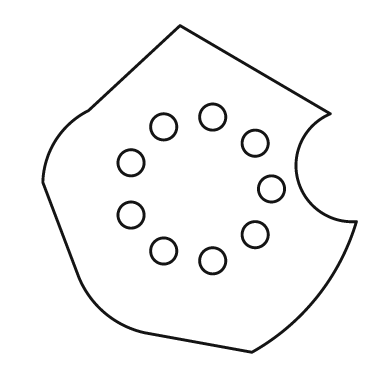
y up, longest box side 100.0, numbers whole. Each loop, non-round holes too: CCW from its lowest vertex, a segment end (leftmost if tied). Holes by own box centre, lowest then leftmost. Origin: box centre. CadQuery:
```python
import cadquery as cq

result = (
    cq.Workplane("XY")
    .moveTo(16.0, -50.0)
    .threePointArc((36.0, -33.0), (48.0, -10.0))
    .threePointArc((30.0, 3.0), (40.0, 23.0))
    .lineTo(-6.0, 50.0)
    .lineTo(-34.0, 24.0)
    .threePointArc((-44.0, 15.0), (-48.0, 2.0))
    .lineTo(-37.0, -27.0)
    .threePointArc((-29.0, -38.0), (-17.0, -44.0))
    .close()
    .moveTo(4.0, -22.0)
    .circle(4.0)
    .moveTo(-11.0, -19.0)
    .circle(4.0)
    .moveTo(17.0, -14.0)
    .circle(4.0)
    .moveTo(-21.0, -8.0)
    .circle(4.0)
    .moveTo(22.0, 0.0)
    .circle(4.0)
    .moveTo(-21.0, 8.0)
    .circle(4.0)
    .moveTo(17.0, 14.0)
    .circle(4.0)
    .moveTo(-11.0, 19.0)
    .circle(4.0)
    .moveTo(4.0, 22.0)
    .circle(4.0)
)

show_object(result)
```